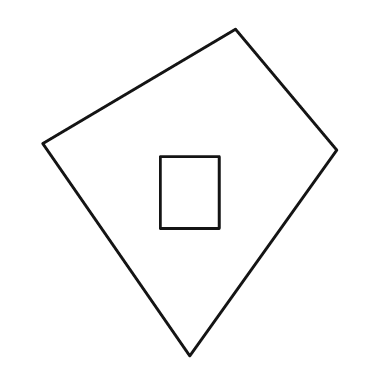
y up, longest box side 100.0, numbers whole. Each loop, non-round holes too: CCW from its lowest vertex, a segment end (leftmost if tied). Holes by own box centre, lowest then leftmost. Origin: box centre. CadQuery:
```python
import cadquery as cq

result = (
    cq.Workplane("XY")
    .moveTo(0.0, -50.0)
    .lineTo(45.0, 13.0)
    .lineTo(14.0, 50.0)
    .lineTo(-45.0, 15.0)
    .close()
    .moveTo(-9.0, -11.0)
    .lineTo(9.0, -11.0)
    .lineTo(9.0, 11.0)
    .lineTo(-9.0, 11.0)
    .close()
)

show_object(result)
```